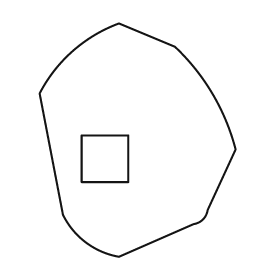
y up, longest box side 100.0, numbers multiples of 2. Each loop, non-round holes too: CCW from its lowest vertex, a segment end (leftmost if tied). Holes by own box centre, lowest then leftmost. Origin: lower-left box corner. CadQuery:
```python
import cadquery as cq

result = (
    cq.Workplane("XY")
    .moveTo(34.0, 0.0)
    .lineTo(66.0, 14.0)
    .threePointArc((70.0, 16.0), (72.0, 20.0))
    .lineTo(84.0, 46.0)
    .threePointArc((74.0, 70.0), (58.0, 90.0))
    .lineTo(34.0, 100.0)
    .threePointArc((14.0, 88.0), (0.0, 70.0))
    .lineTo(10.0, 18.0)
    .threePointArc((20.0, 6.0), (34.0, 0.0))
    .close()
    .moveTo(18.0, 32.0)
    .lineTo(38.0, 32.0)
    .lineTo(38.0, 52.0)
    .lineTo(18.0, 52.0)
    .close()
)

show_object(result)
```